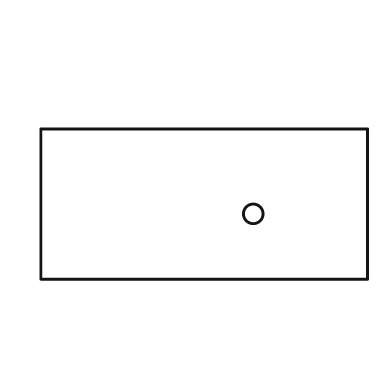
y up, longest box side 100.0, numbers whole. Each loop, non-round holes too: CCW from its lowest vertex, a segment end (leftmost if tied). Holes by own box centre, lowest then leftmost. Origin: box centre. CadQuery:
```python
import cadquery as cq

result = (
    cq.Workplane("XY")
    .moveTo(-50.0, -23.0)
    .lineTo(50.0, -23.0)
    .lineTo(50.0, 23.0)
    .lineTo(-50.0, 23.0)
    .close()
    .moveTo(15.0, -3.0)
    .circle(3.0)
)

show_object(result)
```